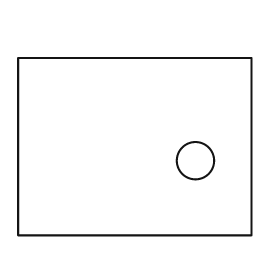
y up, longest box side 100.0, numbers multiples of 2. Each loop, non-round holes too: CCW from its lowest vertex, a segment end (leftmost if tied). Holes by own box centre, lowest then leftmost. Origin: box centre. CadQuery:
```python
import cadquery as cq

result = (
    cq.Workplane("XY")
    .moveTo(-50.0, -38.0)
    .lineTo(50.0, -38.0)
    .lineTo(50.0, 38.0)
    .lineTo(-50.0, 38.0)
    .close()
    .moveTo(26.0, -6.0)
    .circle(8.0)
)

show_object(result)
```